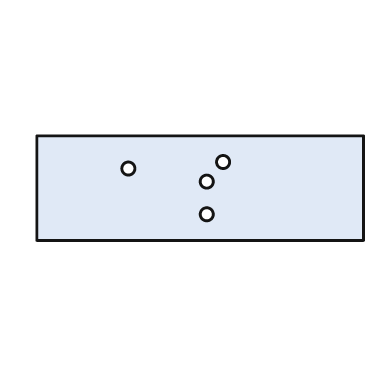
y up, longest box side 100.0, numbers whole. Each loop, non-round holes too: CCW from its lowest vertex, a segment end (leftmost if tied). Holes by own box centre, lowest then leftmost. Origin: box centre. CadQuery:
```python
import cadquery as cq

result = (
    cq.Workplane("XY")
    .moveTo(-50.0, -16.0)
    .lineTo(50.0, -16.0)
    .lineTo(50.0, 16.0)
    .lineTo(-50.0, 16.0)
    .close()
    .moveTo(2.0, -8.0)
    .circle(2.0)
    .moveTo(2.0, 2.0)
    .circle(2.0)
    .moveTo(-22.0, 6.0)
    .circle(2.0)
    .moveTo(7.0, 8.0)
    .circle(2.0)
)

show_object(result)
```